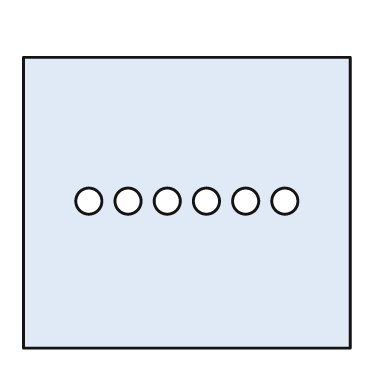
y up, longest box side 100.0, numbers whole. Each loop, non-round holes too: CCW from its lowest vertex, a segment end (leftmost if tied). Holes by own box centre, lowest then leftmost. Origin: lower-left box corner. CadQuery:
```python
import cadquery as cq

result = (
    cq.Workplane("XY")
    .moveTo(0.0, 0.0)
    .lineTo(100.0, 0.0)
    .lineTo(100.0, 89.0)
    .lineTo(0.0, 89.0)
    .close()
    .moveTo(20.0, 45.0)
    .circle(4.0)
    .moveTo(32.0, 45.0)
    .circle(4.0)
    .moveTo(44.0, 45.0)
    .circle(4.0)
    .moveTo(56.0, 45.0)
    .circle(4.0)
    .moveTo(68.0, 45.0)
    .circle(4.0)
    .moveTo(80.0, 45.0)
    .circle(4.0)
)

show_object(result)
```